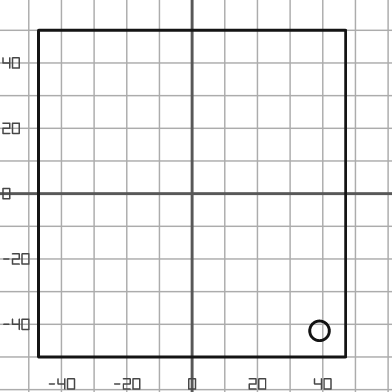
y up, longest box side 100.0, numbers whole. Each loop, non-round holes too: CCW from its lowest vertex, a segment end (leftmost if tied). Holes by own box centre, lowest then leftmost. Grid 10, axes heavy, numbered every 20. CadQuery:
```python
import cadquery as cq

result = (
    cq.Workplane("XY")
    .moveTo(-47.0, -50.0)
    .lineTo(47.0, -50.0)
    .lineTo(47.0, 50.0)
    .lineTo(-47.0, 50.0)
    .close()
    .moveTo(39.0, -42.0)
    .circle(3.0)
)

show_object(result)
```